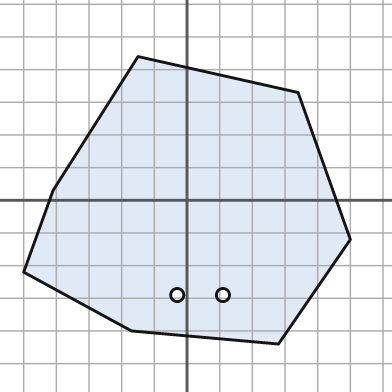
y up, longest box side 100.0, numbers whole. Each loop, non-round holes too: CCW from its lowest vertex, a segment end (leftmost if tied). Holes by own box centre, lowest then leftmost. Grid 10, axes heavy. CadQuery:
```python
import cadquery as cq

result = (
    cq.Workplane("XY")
    .moveTo(28.0, -44.0)
    .lineTo(50.0, -12.0)
    .lineTo(34.0, 33.0)
    .lineTo(-15.0, 44.0)
    .lineTo(-41.0, 3.0)
    .lineTo(-50.0, -22.0)
    .lineTo(-17.0, -40.0)
    .close()
    .moveTo(-3.0, -29.0)
    .circle(2.0)
    .moveTo(11.0, -29.0)
    .circle(2.0)
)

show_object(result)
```